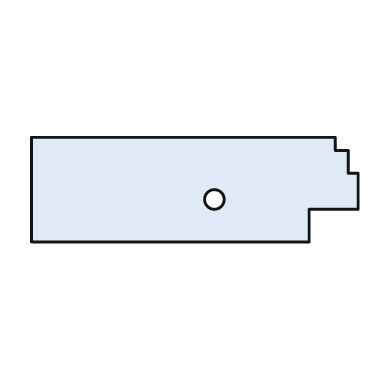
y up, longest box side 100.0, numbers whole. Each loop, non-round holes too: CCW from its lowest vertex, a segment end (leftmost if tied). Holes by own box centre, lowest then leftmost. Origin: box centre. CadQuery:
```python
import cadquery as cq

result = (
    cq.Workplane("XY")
    .moveTo(-50.0, -16.0)
    .lineTo(35.0, -16.0)
    .lineTo(35.0, -6.0)
    .lineTo(50.0, -6.0)
    .lineTo(50.0, 5.0)
    .lineTo(47.0, 5.0)
    .lineTo(47.0, 12.0)
    .lineTo(43.0, 12.0)
    .lineTo(43.0, 16.0)
    .lineTo(-50.0, 16.0)
    .close()
    .moveTo(6.0, -3.0)
    .circle(3.0)
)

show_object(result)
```